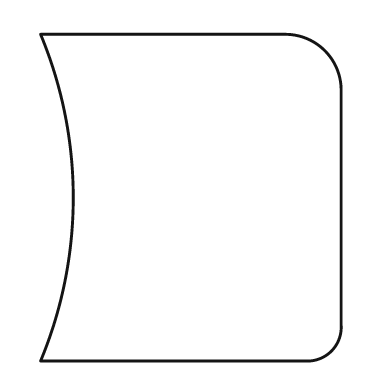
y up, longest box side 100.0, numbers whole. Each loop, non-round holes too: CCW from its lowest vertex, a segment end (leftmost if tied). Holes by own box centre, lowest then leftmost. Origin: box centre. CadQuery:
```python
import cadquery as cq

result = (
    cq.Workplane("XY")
    .moveTo(-46.0, -50.0)
    .lineTo(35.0, -50.0)
    .threePointArc((43.0, -47.0), (46.0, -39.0))
    .lineTo(46.0, 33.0)
    .threePointArc((41.0, 45.0), (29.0, 50.0))
    .lineTo(-46.0, 50.0)
    .threePointArc((-36.0, 0.0), (-46.0, -50.0))
    .close()
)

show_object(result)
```